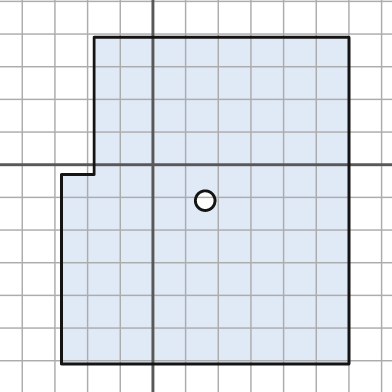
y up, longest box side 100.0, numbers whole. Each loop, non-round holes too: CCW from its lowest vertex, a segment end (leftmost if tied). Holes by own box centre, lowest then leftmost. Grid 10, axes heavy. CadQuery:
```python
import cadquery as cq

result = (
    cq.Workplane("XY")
    .moveTo(-28.0, -61.0)
    .lineTo(60.0, -61.0)
    .lineTo(60.0, 39.0)
    .lineTo(-18.0, 39.0)
    .lineTo(-18.0, -3.0)
    .lineTo(-28.0, -3.0)
    .close()
    .moveTo(16.0, -11.0)
    .circle(3.0)
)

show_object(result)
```